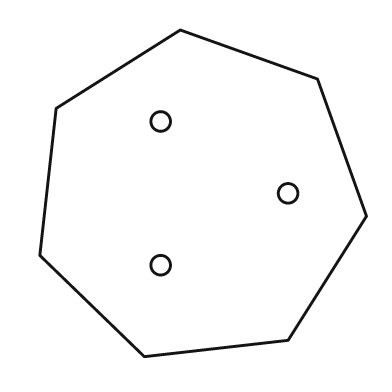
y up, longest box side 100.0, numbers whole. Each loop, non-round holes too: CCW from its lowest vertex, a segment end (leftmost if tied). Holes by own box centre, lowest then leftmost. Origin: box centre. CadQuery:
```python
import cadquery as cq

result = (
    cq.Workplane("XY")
    .moveTo(-18.0, -50.0)
    .lineTo(26.0, -45.0)
    .lineTo(50.0, -7.0)
    .lineTo(35.0, 35.0)
    .lineTo(-7.0, 50.0)
    .lineTo(-45.0, 26.0)
    .lineTo(-50.0, -19.0)
    .close()
    .moveTo(-13.0, -22.0)
    .circle(3.0)
    .moveTo(26.0, 0.0)
    .circle(3.0)
    .moveTo(-13.0, 22.0)
    .circle(3.0)
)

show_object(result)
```